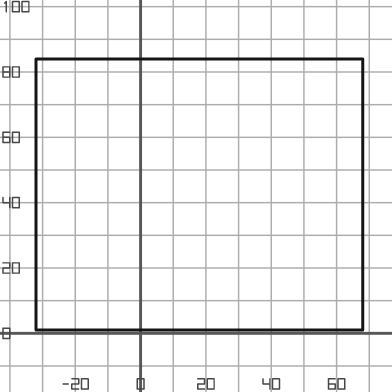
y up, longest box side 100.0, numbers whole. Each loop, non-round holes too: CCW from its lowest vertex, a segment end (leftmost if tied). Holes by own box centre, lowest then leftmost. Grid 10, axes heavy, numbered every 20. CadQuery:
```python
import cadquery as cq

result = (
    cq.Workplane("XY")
    .moveTo(-32.0, 1.0)
    .lineTo(68.0, 1.0)
    .lineTo(68.0, 84.0)
    .lineTo(-32.0, 84.0)
    .close()
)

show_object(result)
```